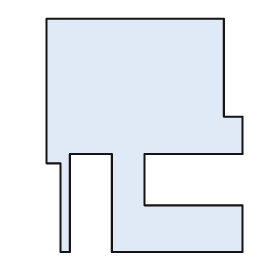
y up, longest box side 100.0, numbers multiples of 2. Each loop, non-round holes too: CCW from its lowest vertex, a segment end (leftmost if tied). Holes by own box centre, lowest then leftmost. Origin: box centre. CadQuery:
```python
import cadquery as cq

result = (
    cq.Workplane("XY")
    .moveTo(-36.0, -50.0)
    .lineTo(-32.0, -50.0)
    .lineTo(-32.0, -8.0)
    .lineTo(-14.0, -8.0)
    .lineTo(-14.0, -50.0)
    .lineTo(42.0, -50.0)
    .lineTo(42.0, -30.0)
    .lineTo(0.0, -30.0)
    .lineTo(0.0, -8.0)
    .lineTo(42.0, -8.0)
    .lineTo(42.0, 8.0)
    .lineTo(34.0, 8.0)
    .lineTo(34.0, 50.0)
    .lineTo(-42.0, 50.0)
    .lineTo(-42.0, -12.0)
    .lineTo(-36.0, -12.0)
    .close()
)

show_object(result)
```